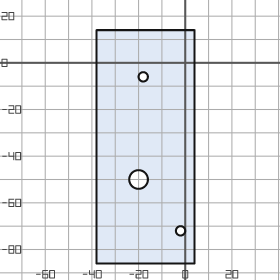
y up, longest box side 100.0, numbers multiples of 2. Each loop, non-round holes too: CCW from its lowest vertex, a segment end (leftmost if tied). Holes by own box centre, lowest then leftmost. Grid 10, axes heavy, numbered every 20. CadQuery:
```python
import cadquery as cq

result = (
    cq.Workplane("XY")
    .moveTo(-38.0, -86.0)
    .lineTo(4.0, -86.0)
    .lineTo(4.0, 14.0)
    .lineTo(-38.0, 14.0)
    .close()
    .moveTo(-2.0, -72.0)
    .circle(2.0)
    .moveTo(-20.0, -50.0)
    .circle(4.0)
    .moveTo(-18.0, -6.0)
    .circle(2.0)
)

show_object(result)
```